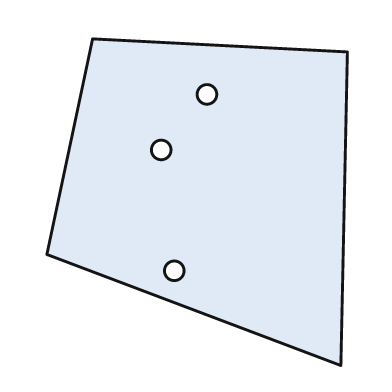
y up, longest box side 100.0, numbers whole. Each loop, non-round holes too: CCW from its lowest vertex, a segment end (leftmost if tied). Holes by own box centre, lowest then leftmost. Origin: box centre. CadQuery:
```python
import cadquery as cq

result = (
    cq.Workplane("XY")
    .moveTo(44.0, -50.0)
    .lineTo(46.0, 46.0)
    .lineTo(-32.0, 50.0)
    .lineTo(-46.0, -16.0)
    .close()
    .moveTo(-7.0, -21.0)
    .circle(3.0)
    .moveTo(-11.0, 16.0)
    .circle(3.0)
    .moveTo(3.0, 33.0)
    .circle(3.0)
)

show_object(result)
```